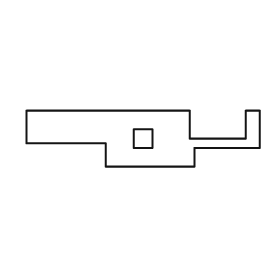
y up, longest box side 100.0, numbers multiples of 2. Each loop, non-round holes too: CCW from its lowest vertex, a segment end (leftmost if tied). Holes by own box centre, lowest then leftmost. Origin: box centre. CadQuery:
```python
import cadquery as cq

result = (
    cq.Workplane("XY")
    .moveTo(-16.0, -12.0)
    .lineTo(22.0, -12.0)
    .lineTo(22.0, -4.0)
    .lineTo(50.0, -4.0)
    .lineTo(50.0, 12.0)
    .lineTo(44.0, 12.0)
    .lineTo(44.0, 0.0)
    .lineTo(20.0, 0.0)
    .lineTo(20.0, 12.0)
    .lineTo(-50.0, 12.0)
    .lineTo(-50.0, -2.0)
    .lineTo(-16.0, -2.0)
    .close()
    .moveTo(-4.0, -4.0)
    .lineTo(4.0, -4.0)
    .lineTo(4.0, 4.0)
    .lineTo(-4.0, 4.0)
    .close()
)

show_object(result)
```